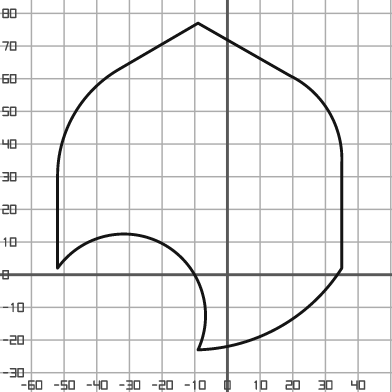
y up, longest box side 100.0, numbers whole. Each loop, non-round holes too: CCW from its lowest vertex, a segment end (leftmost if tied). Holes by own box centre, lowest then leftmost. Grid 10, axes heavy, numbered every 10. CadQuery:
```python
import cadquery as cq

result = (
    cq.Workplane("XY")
    .moveTo(-9.0, -23.0)
    .threePointArc((16.0, -16.0), (35.0, 2.0))
    .lineTo(35.0, 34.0)
    .threePointArc((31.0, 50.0), (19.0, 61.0))
    .lineTo(-9.0, 77.0)
    .lineTo(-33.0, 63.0)
    .threePointArc((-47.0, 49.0), (-52.0, 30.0))
    .lineTo(-52.0, 2.0)
    .threePointArc((-19.0, 9.0), (-9.0, -23.0))
    .close()
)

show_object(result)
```